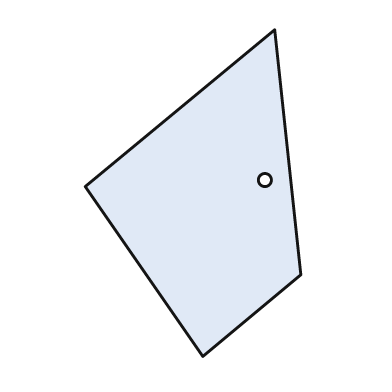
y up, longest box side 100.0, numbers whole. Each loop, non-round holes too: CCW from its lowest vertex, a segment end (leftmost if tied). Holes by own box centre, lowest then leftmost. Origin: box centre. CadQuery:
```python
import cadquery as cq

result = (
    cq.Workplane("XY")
    .moveTo(3.0, -50.0)
    .lineTo(33.0, -25.0)
    .lineTo(25.0, 50.0)
    .lineTo(-33.0, 2.0)
    .close()
    .moveTo(22.0, 4.0)
    .circle(2.0)
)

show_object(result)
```